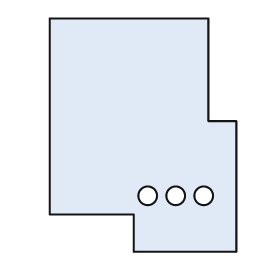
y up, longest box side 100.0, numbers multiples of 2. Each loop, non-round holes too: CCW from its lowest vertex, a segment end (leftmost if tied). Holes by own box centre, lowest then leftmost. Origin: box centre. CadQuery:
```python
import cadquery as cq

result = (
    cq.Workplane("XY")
    .moveTo(-4.0, -50.0)
    .lineTo(40.0, -50.0)
    .lineTo(40.0, 6.0)
    .lineTo(28.0, 6.0)
    .lineTo(28.0, 50.0)
    .lineTo(-40.0, 50.0)
    .lineTo(-40.0, -34.0)
    .lineTo(-4.0, -34.0)
    .close()
    .moveTo(2.0, -26.0)
    .circle(4.0)
    .moveTo(14.0, -26.0)
    .circle(4.0)
    .moveTo(26.0, -26.0)
    .circle(4.0)
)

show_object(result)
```